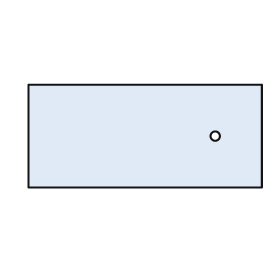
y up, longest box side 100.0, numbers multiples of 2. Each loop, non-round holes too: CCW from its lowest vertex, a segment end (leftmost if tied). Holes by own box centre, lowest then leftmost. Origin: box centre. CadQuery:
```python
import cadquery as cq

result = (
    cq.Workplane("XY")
    .moveTo(-50.0, -22.0)
    .lineTo(50.0, -22.0)
    .lineTo(50.0, 22.0)
    .lineTo(-50.0, 22.0)
    .close()
    .moveTo(30.0, 0.0)
    .circle(2.0)
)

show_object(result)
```